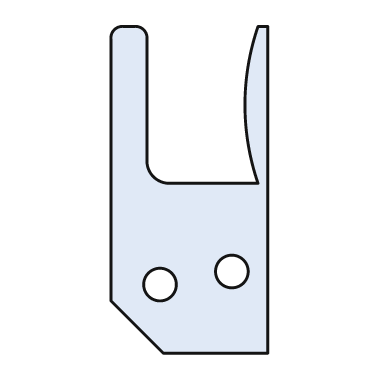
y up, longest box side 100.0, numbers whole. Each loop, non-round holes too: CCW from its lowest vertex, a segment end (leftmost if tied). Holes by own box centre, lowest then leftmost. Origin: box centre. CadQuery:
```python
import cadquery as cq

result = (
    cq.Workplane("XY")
    .moveTo(-8.0, -50.0)
    .lineTo(24.0, -50.0)
    .lineTo(24.0, 50.0)
    .lineTo(21.0, 50.0)
    .threePointArc((17.0, 26.0), (21.0, 2.0))
    .lineTo(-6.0, 2.0)
    .threePointArc((-11.0, 4.0), (-13.0, 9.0))
    .lineTo(-13.0, 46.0)
    .threePointArc((-14.0, 49.0), (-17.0, 50.0))
    .lineTo(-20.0, 50.0)
    .threePointArc((-23.0, 49.0), (-24.0, 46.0))
    .lineTo(-24.0, -34.0)
    .close()
    .moveTo(-9.0, -29.0)
    .circle(5.0)
    .moveTo(13.0, -25.0)
    .circle(5.0)
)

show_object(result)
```